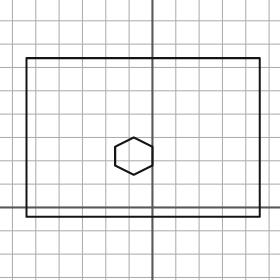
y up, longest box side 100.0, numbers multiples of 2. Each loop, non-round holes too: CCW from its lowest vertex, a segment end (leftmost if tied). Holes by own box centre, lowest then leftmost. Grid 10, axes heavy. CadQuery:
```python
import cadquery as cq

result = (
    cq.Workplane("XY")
    .moveTo(-54.0, -4.0)
    .lineTo(46.0, -4.0)
    .lineTo(46.0, 64.0)
    .lineTo(-54.0, 64.0)
    .close()
    .moveTo(-8.0, 14.0)
    .lineTo(0.0, 18.0)
    .lineTo(0.0, 26.0)
    .lineTo(-8.0, 30.0)
    .lineTo(-16.0, 26.0)
    .lineTo(-16.0, 18.0)
    .close()
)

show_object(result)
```